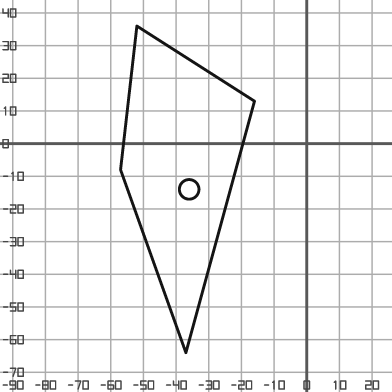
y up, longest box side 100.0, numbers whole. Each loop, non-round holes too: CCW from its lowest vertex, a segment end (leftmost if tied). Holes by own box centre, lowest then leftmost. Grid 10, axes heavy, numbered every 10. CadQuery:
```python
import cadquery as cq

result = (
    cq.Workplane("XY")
    .moveTo(-37.0, -64.0)
    .lineTo(-16.0, 13.0)
    .lineTo(-52.0, 36.0)
    .lineTo(-57.0, -8.0)
    .close()
    .moveTo(-36.0, -14.0)
    .circle(3.0)
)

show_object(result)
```